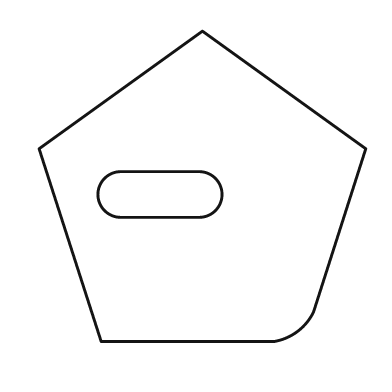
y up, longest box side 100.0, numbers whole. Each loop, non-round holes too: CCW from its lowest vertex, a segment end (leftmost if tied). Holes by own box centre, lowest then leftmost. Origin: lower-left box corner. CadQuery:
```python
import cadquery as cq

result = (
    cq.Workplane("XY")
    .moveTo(19.0, 0.0)
    .lineTo(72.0, 0.0)
    .threePointArc((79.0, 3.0), (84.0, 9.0))
    .lineTo(100.0, 59.0)
    .lineTo(50.0, 95.0)
    .lineTo(0.0, 59.0)
    .close()
    .moveTo(25.0, 38.0)
    .lineTo(49.0, 38.0)
    .threePointArc((56.0, 45.0), (49.0, 52.0))
    .lineTo(25.0, 52.0)
    .threePointArc((18.0, 45.0), (25.0, 38.0))
    .close()
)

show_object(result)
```